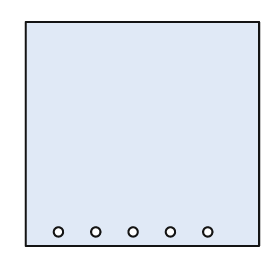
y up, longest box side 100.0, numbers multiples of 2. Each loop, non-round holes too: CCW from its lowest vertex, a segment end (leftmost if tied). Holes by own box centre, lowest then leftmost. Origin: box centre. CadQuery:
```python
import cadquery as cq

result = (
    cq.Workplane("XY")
    .moveTo(-50.0, -48.0)
    .lineTo(50.0, -48.0)
    .lineTo(50.0, 48.0)
    .lineTo(-50.0, 48.0)
    .close()
    .moveTo(-36.0, -42.0)
    .circle(2.0)
    .moveTo(-20.0, -42.0)
    .circle(2.0)
    .moveTo(-4.0, -42.0)
    .circle(2.0)
    .moveTo(12.0, -42.0)
    .circle(2.0)
    .moveTo(28.0, -42.0)
    .circle(2.0)
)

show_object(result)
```